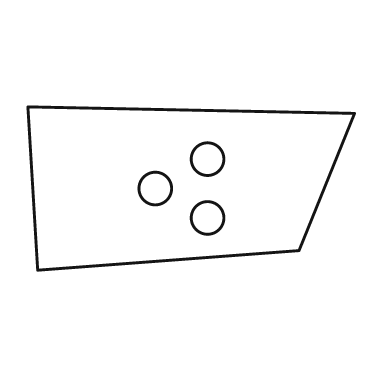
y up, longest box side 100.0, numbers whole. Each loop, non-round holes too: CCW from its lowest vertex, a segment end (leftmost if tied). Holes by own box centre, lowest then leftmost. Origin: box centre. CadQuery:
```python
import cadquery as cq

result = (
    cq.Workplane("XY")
    .moveTo(-47.0, -25.0)
    .lineTo(33.0, -19.0)
    .lineTo(50.0, 23.0)
    .lineTo(-50.0, 25.0)
    .close()
    .moveTo(5.0, -9.0)
    .circle(5.0)
    .moveTo(-11.0, 0.0)
    .circle(5.0)
    .moveTo(5.0, 9.0)
    .circle(5.0)
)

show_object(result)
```